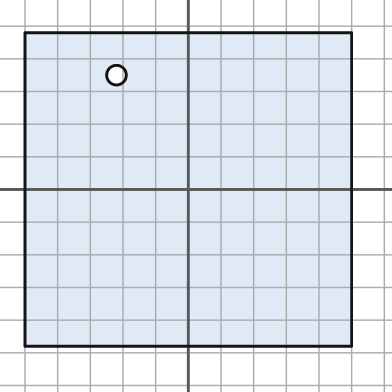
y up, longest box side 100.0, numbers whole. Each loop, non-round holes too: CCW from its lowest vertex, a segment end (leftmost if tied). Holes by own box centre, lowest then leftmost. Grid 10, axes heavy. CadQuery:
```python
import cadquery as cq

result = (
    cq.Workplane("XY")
    .moveTo(-50.0, -48.0)
    .lineTo(50.0, -48.0)
    .lineTo(50.0, 48.0)
    .lineTo(-50.0, 48.0)
    .close()
    .moveTo(-22.0, 35.0)
    .circle(3.0)
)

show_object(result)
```